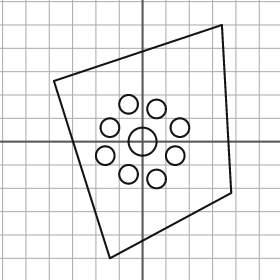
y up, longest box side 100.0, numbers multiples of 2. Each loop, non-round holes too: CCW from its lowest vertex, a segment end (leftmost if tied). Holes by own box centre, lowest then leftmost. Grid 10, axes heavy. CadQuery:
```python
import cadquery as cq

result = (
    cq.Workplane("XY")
    .moveTo(-14.0, -50.0)
    .lineTo(38.0, -22.0)
    .lineTo(34.0, 50.0)
    .lineTo(-38.0, 26.0)
    .close()
    .moveTo(6.0, -16.0)
    .circle(4.0)
    .moveTo(-6.0, -14.0)
    .circle(4.0)
    .moveTo(-16.0, -6.0)
    .circle(4.0)
    .moveTo(14.0, -6.0)
    .circle(4.0)
    .moveTo(0.0, 0.0)
    .circle(6.0)
    .moveTo(-14.0, 6.0)
    .circle(4.0)
    .moveTo(16.0, 6.0)
    .circle(4.0)
    .moveTo(6.0, 14.0)
    .circle(4.0)
    .moveTo(-6.0, 16.0)
    .circle(4.0)
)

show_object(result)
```